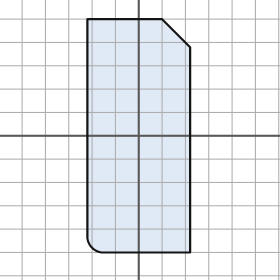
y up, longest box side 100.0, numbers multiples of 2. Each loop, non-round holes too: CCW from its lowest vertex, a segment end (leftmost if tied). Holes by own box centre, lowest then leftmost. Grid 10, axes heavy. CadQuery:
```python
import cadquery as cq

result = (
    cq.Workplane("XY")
    .moveTo(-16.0, -50.0)
    .lineTo(22.0, -50.0)
    .lineTo(22.0, 38.0)
    .lineTo(10.0, 50.0)
    .lineTo(-22.0, 50.0)
    .lineTo(-22.0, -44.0)
    .threePointArc((-20.0, -48.0), (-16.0, -50.0))
    .close()
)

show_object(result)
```